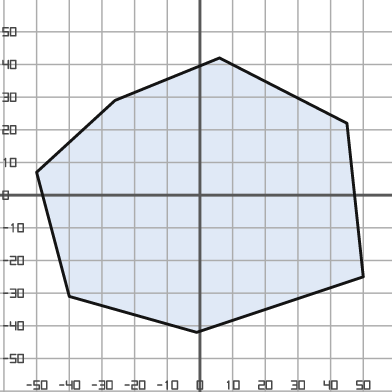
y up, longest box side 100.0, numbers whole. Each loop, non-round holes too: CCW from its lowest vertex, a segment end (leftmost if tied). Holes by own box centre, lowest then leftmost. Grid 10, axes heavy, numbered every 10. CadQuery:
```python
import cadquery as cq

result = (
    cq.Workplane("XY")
    .moveTo(-1.0, -42.0)
    .lineTo(50.0, -25.0)
    .lineTo(45.0, 22.0)
    .lineTo(6.0, 42.0)
    .lineTo(-26.0, 29.0)
    .lineTo(-50.0, 7.0)
    .lineTo(-40.0, -31.0)
    .close()
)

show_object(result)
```